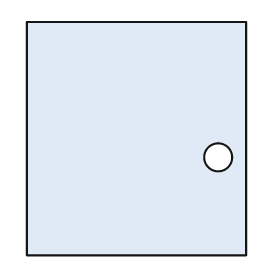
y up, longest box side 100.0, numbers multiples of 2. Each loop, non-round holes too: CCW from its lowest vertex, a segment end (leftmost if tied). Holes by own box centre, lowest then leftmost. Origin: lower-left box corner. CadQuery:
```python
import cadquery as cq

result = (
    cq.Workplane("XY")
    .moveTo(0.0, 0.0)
    .lineTo(94.0, 0.0)
    .lineTo(94.0, 100.0)
    .lineTo(0.0, 100.0)
    .close()
    .moveTo(82.0, 42.0)
    .circle(6.0)
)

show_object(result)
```